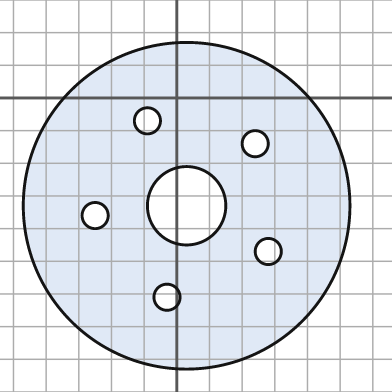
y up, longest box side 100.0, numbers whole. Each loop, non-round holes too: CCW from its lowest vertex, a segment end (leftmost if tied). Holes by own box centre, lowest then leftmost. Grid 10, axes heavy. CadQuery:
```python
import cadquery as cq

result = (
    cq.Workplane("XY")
    .moveTo(3.0, -33.0)
    .circle(50.0)
    .moveTo(-3.0, -61.0)
    .circle(4.0)
    .moveTo(28.0, -47.0)
    .circle(4.0)
    .moveTo(-25.0, -36.0)
    .circle(4.0)
    .moveTo(3.0, -33.0)
    .circle(12.0)
    .moveTo(24.0, -14.0)
    .circle(4.0)
    .moveTo(-9.0, -7.0)
    .circle(4.0)
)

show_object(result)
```